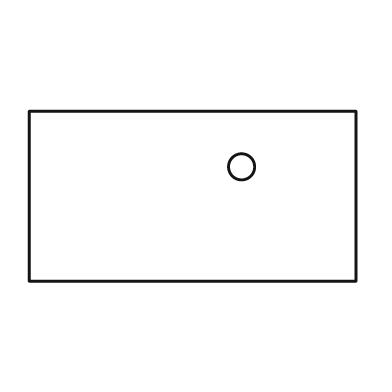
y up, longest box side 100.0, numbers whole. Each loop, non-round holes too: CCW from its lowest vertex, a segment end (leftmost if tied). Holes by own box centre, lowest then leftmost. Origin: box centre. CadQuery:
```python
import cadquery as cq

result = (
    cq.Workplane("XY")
    .moveTo(-50.0, -26.0)
    .lineTo(50.0, -26.0)
    .lineTo(50.0, 26.0)
    .lineTo(-50.0, 26.0)
    .close()
    .moveTo(15.0, 9.0)
    .circle(4.0)
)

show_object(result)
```